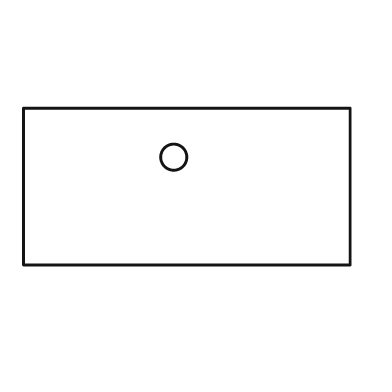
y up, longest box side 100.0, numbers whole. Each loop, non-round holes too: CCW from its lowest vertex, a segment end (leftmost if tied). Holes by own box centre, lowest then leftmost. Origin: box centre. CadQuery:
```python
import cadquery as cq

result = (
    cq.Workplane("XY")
    .moveTo(-50.0, -24.0)
    .lineTo(50.0, -24.0)
    .lineTo(50.0, 24.0)
    .lineTo(-50.0, 24.0)
    .close()
    .moveTo(-4.0, 9.0)
    .circle(4.0)
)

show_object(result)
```